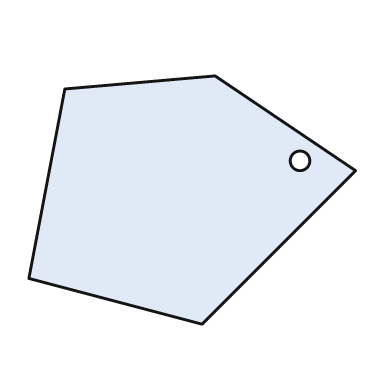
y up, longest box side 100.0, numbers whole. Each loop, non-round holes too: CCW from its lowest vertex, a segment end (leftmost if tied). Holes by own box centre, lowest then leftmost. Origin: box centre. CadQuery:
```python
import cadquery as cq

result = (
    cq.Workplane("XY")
    .moveTo(3.0, -38.0)
    .lineTo(50.0, 9.0)
    .lineTo(7.0, 38.0)
    .lineTo(-39.0, 34.0)
    .lineTo(-50.0, -24.0)
    .close()
    .moveTo(33.0, 12.0)
    .circle(3.0)
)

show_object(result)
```